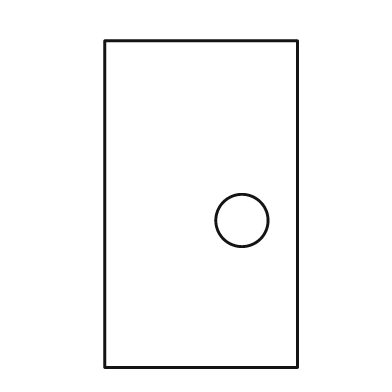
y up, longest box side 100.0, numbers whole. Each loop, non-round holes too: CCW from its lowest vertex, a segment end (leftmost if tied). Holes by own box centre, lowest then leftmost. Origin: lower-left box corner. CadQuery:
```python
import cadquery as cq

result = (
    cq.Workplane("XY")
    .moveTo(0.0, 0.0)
    .lineTo(59.0, 0.0)
    .lineTo(59.0, 100.0)
    .lineTo(0.0, 100.0)
    .close()
    .moveTo(42.0, 45.0)
    .circle(8.0)
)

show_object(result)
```